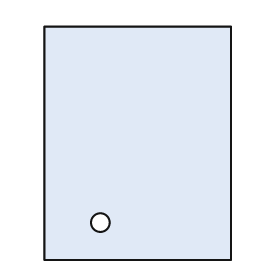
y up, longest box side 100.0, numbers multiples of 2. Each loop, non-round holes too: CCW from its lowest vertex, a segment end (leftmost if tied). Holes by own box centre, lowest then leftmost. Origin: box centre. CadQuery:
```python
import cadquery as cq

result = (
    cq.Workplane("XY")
    .moveTo(-40.0, -50.0)
    .lineTo(40.0, -50.0)
    .lineTo(40.0, 50.0)
    .lineTo(-40.0, 50.0)
    .close()
    .moveTo(-16.0, -34.0)
    .circle(4.0)
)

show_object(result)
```